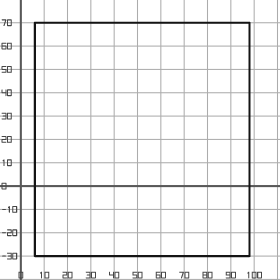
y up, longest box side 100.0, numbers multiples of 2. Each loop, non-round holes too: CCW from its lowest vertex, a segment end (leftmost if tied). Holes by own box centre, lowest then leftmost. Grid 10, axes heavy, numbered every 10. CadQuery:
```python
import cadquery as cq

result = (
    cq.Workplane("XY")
    .moveTo(6.0, -30.0)
    .lineTo(98.0, -30.0)
    .lineTo(98.0, 70.0)
    .lineTo(6.0, 70.0)
    .close()
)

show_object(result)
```